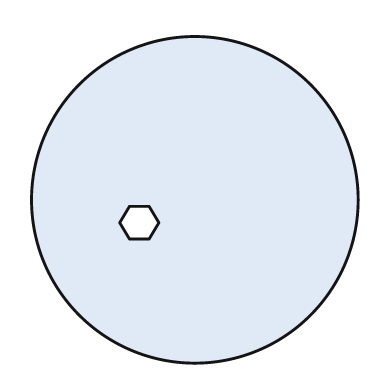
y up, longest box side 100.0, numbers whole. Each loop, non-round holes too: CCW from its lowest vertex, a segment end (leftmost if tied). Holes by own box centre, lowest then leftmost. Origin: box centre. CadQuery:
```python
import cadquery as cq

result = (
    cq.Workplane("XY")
    .moveTo(0.0, 0.0)
    .circle(50.0)
    .moveTo(-20.0, -12.0)
    .lineTo(-14.0, -12.0)
    .lineTo(-11.0, -7.0)
    .lineTo(-14.0, -2.0)
    .lineTo(-20.0, -2.0)
    .lineTo(-23.0, -7.0)
    .close()
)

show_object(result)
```